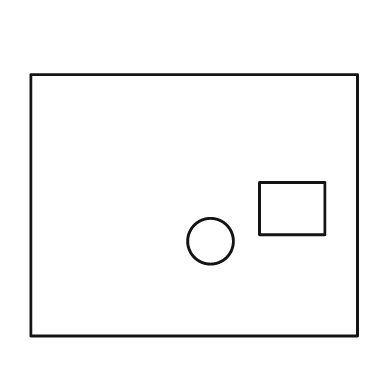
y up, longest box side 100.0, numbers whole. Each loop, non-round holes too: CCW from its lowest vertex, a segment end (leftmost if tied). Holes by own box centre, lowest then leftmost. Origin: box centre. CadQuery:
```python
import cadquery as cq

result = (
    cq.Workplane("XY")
    .moveTo(-50.0, -40.0)
    .lineTo(50.0, -40.0)
    .lineTo(50.0, 40.0)
    .lineTo(-50.0, 40.0)
    .close()
    .moveTo(5.0, -11.0)
    .circle(7.0)
    .moveTo(20.0, -9.0)
    .lineTo(40.0, -9.0)
    .lineTo(40.0, 7.0)
    .lineTo(20.0, 7.0)
    .close()
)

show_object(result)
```